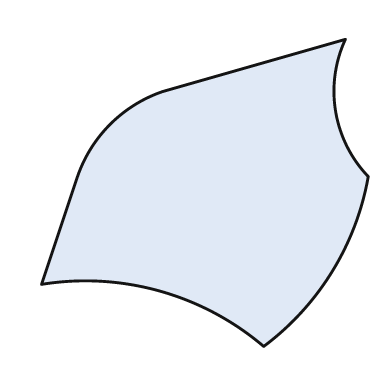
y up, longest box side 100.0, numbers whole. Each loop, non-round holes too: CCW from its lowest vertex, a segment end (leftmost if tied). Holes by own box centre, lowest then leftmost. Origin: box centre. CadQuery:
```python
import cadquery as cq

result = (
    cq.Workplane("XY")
    .moveTo(18.0, -47.0)
    .threePointArc((39.0, -24.0), (50.0, 5.0))
    .threePointArc((40.0, 25.0), (43.0, 47.0))
    .lineTo(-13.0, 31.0)
    .threePointArc((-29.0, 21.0), (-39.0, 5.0))
    .lineTo(-50.0, -28.0)
    .threePointArc((-14.0, -30.0), (18.0, -47.0))
    .close()
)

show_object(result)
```